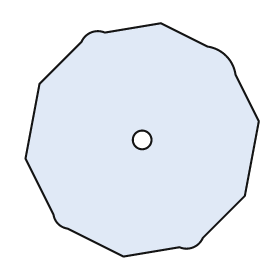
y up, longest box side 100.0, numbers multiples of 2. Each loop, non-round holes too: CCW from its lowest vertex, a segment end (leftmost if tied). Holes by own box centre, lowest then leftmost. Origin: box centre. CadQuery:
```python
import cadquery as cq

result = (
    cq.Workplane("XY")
    .moveTo(-8.0, -50.0)
    .lineTo(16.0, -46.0)
    .threePointArc((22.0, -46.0), (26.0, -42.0))
    .lineTo(44.0, -24.0)
    .lineTo(50.0, 8.0)
    .lineTo(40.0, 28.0)
    .threePointArc((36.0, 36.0), (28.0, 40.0))
    .lineTo(8.0, 50.0)
    .lineTo(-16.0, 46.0)
    .threePointArc((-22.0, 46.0), (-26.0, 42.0))
    .lineTo(-44.0, 24.0)
    .lineTo(-50.0, -8.0)
    .lineTo(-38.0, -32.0)
    .threePointArc((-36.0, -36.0), (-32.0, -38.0))
    .close()
    .moveTo(0.0, 0.0)
    .circle(4.0)
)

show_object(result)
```